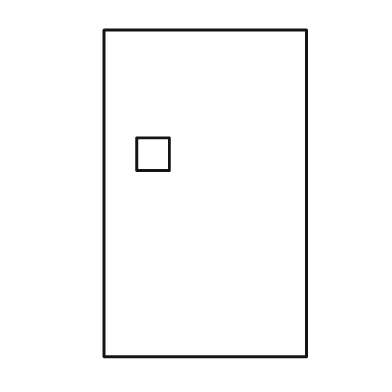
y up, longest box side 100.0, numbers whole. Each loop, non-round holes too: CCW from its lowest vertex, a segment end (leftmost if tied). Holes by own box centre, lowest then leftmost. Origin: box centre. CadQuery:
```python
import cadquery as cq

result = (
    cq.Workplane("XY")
    .moveTo(-31.0, -50.0)
    .lineTo(31.0, -50.0)
    .lineTo(31.0, 50.0)
    .lineTo(-31.0, 50.0)
    .close()
    .moveTo(-21.0, 7.0)
    .lineTo(-11.0, 7.0)
    .lineTo(-11.0, 17.0)
    .lineTo(-21.0, 17.0)
    .close()
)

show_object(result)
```